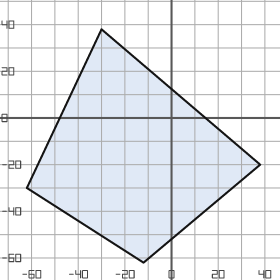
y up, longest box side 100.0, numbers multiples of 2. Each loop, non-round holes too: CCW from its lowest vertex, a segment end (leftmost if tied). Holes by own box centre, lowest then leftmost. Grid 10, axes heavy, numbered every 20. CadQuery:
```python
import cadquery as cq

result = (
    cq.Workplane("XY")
    .moveTo(-12.0, -62.0)
    .lineTo(38.0, -20.0)
    .lineTo(-30.0, 38.0)
    .lineTo(-62.0, -30.0)
    .close()
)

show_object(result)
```